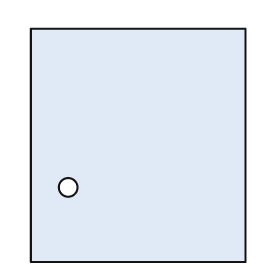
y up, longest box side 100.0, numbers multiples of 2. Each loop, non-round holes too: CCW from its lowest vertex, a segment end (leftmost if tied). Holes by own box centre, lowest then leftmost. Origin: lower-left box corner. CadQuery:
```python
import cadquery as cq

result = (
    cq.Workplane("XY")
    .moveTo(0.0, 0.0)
    .lineTo(92.0, 0.0)
    .lineTo(92.0, 100.0)
    .lineTo(0.0, 100.0)
    .close()
    .moveTo(16.0, 32.0)
    .circle(4.0)
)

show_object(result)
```